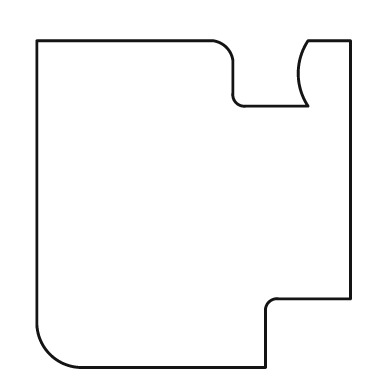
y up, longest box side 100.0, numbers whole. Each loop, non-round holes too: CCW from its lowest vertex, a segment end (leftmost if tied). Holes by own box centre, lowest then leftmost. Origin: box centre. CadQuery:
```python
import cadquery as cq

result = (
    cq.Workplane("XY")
    .moveTo(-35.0, -50.0)
    .lineTo(22.0, -50.0)
    .lineTo(22.0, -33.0)
    .threePointArc((23.0, -30.0), (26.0, -29.0))
    .lineTo(48.0, -29.0)
    .lineTo(48.0, 50.0)
    .lineTo(35.0, 50.0)
    .threePointArc((32.0, 40.0), (35.0, 30.0))
    .lineTo(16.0, 30.0)
    .threePointArc((13.0, 31.0), (12.0, 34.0))
    .lineTo(12.0, 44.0)
    .threePointArc((10.0, 48.0), (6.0, 50.0))
    .lineTo(-48.0, 50.0)
    .lineTo(-48.0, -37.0)
    .threePointArc((-44.0, -46.0), (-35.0, -50.0))
    .close()
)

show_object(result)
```